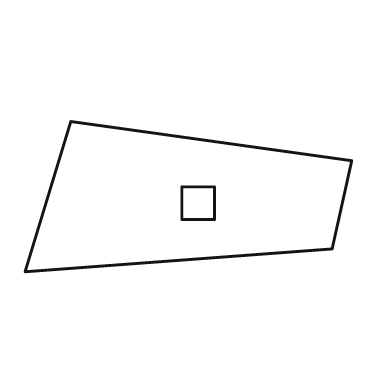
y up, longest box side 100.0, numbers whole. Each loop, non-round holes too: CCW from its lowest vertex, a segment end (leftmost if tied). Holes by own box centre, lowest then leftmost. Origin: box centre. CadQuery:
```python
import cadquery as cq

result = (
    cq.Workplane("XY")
    .moveTo(-50.0, -23.0)
    .lineTo(44.0, -16.0)
    .lineTo(50.0, 11.0)
    .lineTo(-36.0, 23.0)
    .close()
    .moveTo(-2.0, -7.0)
    .lineTo(8.0, -7.0)
    .lineTo(8.0, 3.0)
    .lineTo(-2.0, 3.0)
    .close()
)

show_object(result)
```